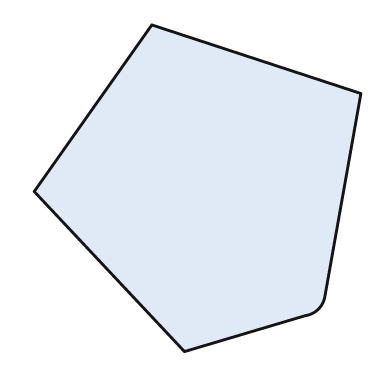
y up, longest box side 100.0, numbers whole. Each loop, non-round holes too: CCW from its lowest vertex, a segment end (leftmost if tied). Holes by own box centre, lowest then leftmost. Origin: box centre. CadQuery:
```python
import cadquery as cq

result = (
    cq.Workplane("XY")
    .moveTo(-4.0, -50.0)
    .lineTo(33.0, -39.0)
    .threePointArc((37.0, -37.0), (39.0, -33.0))
    .lineTo(50.0, 29.0)
    .lineTo(-14.0, 50.0)
    .lineTo(-50.0, -1.0)
    .close()
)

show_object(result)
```